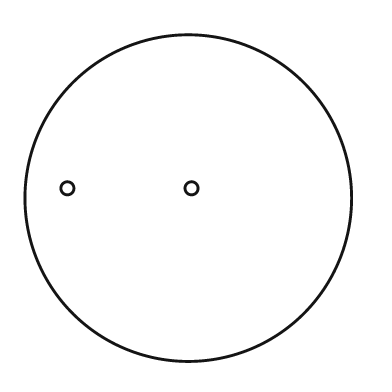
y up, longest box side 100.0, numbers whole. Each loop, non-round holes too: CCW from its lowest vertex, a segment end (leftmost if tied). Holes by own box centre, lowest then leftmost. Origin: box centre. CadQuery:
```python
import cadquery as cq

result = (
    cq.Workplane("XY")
    .moveTo(0.0, 0.0)
    .circle(50.0)
    .moveTo(-37.0, 3.0)
    .circle(2.0)
    .moveTo(1.0, 3.0)
    .circle(2.0)
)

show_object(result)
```